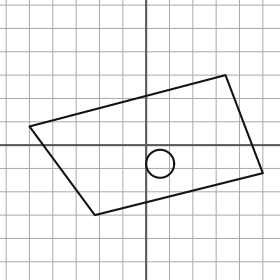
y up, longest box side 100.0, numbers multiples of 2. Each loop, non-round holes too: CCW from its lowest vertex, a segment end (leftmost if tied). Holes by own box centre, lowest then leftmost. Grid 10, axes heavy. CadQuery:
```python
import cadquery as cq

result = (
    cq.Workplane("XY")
    .moveTo(-22.0, -30.0)
    .lineTo(50.0, -12.0)
    .lineTo(34.0, 30.0)
    .lineTo(-50.0, 8.0)
    .close()
    .moveTo(6.0, -8.0)
    .circle(6.0)
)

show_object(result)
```